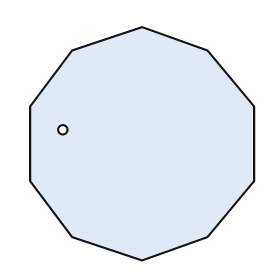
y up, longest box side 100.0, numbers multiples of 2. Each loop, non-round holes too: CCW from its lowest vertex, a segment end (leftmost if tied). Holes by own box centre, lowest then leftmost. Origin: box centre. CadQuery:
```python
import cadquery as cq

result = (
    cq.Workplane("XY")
    .moveTo(0.0, -50.0)
    .lineTo(28.0, -40.0)
    .lineTo(48.0, -16.0)
    .lineTo(48.0, 16.0)
    .lineTo(28.0, 40.0)
    .lineTo(0.0, 50.0)
    .lineTo(-30.0, 40.0)
    .lineTo(-48.0, 16.0)
    .lineTo(-48.0, -16.0)
    .lineTo(-30.0, -40.0)
    .close()
    .moveTo(-34.0, 6.0)
    .circle(2.0)
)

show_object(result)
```